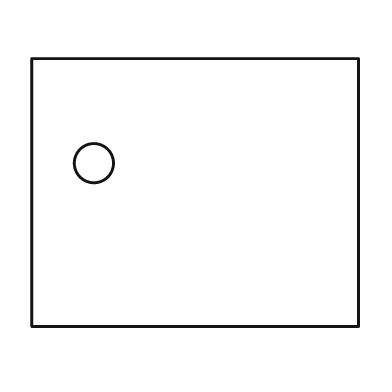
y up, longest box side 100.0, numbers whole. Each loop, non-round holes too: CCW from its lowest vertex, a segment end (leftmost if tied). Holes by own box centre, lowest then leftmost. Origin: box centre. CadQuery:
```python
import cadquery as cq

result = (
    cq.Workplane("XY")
    .moveTo(-50.0, -41.0)
    .lineTo(50.0, -41.0)
    .lineTo(50.0, 41.0)
    .lineTo(-50.0, 41.0)
    .close()
    .moveTo(-31.0, 9.0)
    .circle(6.0)
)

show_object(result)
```